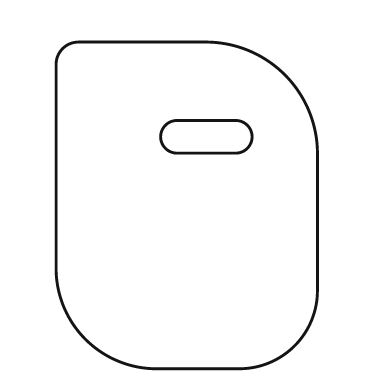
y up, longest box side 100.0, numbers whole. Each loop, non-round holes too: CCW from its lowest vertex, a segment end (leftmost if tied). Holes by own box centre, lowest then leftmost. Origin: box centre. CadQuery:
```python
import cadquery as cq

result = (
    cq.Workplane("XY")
    .moveTo(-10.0, -50.0)
    .lineTo(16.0, -50.0)
    .threePointArc((33.0, -43.0), (40.0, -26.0))
    .lineTo(40.0, 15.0)
    .threePointArc((30.0, 40.0), (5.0, 50.0))
    .lineTo(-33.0, 50.0)
    .threePointArc((-38.0, 48.0), (-40.0, 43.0))
    .lineTo(-40.0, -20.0)
    .threePointArc((-31.0, -41.0), (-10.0, -50.0))
    .close()
    .moveTo(-3.0, 16.0)
    .lineTo(15.0, 16.0)
    .threePointArc((20.0, 21.0), (15.0, 26.0))
    .lineTo(-3.0, 26.0)
    .threePointArc((-8.0, 21.0), (-3.0, 16.0))
    .close()
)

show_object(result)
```